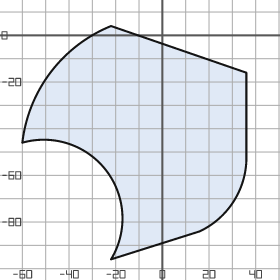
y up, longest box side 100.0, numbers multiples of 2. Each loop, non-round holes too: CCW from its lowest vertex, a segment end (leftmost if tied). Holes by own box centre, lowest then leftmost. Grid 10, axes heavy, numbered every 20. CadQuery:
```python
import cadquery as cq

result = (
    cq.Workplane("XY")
    .moveTo(-22.0, -96.0)
    .lineTo(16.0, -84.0)
    .threePointArc((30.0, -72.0), (36.0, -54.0))
    .lineTo(36.0, -16.0)
    .lineTo(-22.0, 4.0)
    .threePointArc((-48.0, -16.0), (-60.0, -46.0))
    .threePointArc((-24.0, -58.0), (-22.0, -96.0))
    .close()
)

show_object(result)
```